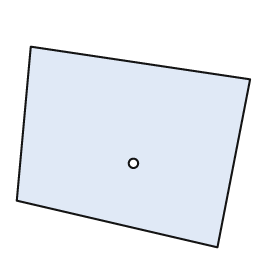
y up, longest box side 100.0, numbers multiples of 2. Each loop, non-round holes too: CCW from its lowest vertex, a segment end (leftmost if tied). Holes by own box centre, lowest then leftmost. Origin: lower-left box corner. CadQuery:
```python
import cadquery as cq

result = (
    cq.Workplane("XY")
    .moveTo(86.0, 0.0)
    .lineTo(100.0, 72.0)
    .lineTo(6.0, 86.0)
    .lineTo(0.0, 20.0)
    .close()
    .moveTo(50.0, 36.0)
    .circle(2.0)
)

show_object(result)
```